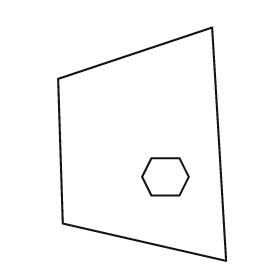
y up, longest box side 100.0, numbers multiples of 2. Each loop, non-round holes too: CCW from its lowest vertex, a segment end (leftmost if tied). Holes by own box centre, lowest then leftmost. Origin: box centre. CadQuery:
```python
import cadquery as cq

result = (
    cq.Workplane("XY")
    .moveTo(36.0, -50.0)
    .lineTo(30.0, 50.0)
    .lineTo(-36.0, 28.0)
    .lineTo(-34.0, -34.0)
    .close()
    .moveTo(4.0, -22.0)
    .lineTo(16.0, -22.0)
    .lineTo(20.0, -14.0)
    .lineTo(16.0, -6.0)
    .lineTo(4.0, -6.0)
    .lineTo(0.0, -14.0)
    .close()
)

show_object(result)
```